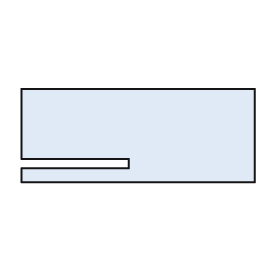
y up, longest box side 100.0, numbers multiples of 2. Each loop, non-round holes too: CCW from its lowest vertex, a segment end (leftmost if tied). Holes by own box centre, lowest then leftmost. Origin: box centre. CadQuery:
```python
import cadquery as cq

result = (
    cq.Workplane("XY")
    .moveTo(-50.0, -20.0)
    .lineTo(50.0, -20.0)
    .lineTo(50.0, 20.0)
    .lineTo(-50.0, 20.0)
    .lineTo(-50.0, -10.0)
    .lineTo(-4.0, -10.0)
    .lineTo(-4.0, -14.0)
    .lineTo(-50.0, -14.0)
    .close()
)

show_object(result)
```